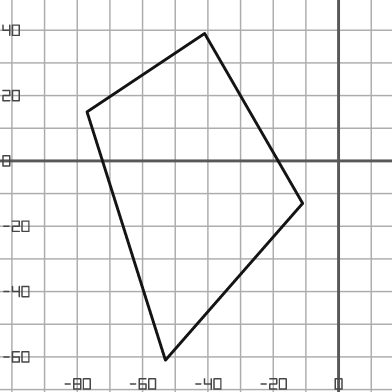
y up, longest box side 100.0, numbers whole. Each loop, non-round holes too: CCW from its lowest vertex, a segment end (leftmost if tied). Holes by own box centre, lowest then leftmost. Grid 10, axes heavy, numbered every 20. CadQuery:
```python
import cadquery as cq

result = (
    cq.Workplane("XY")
    .moveTo(-53.0, -61.0)
    .lineTo(-11.0, -13.0)
    .lineTo(-41.0, 39.0)
    .lineTo(-77.0, 15.0)
    .close()
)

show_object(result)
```